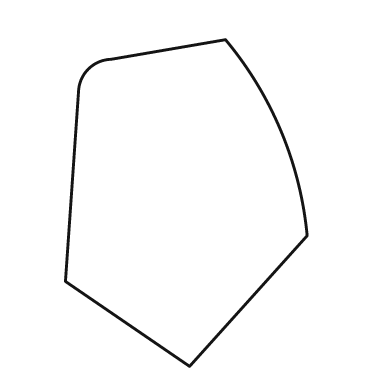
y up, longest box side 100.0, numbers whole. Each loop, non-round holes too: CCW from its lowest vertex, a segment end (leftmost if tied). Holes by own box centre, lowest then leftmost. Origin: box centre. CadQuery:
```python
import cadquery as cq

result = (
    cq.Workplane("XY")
    .moveTo(1.0, -50.0)
    .lineTo(37.0, -10.0)
    .threePointArc((29.0, 22.0), (12.0, 50.0))
    .lineTo(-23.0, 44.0)
    .threePointArc((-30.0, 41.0), (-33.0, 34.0))
    .lineTo(-37.0, -24.0)
    .close()
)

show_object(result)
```